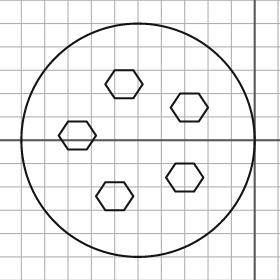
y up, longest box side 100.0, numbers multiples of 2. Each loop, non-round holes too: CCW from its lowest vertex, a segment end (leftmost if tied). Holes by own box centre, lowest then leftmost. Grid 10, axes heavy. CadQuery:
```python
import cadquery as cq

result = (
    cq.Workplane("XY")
    .moveTo(-50.0, 0.0)
    .circle(50.0)
    .moveTo(-64.0, -30.0)
    .lineTo(-56.0, -30.0)
    .lineTo(-52.0, -24.0)
    .lineTo(-56.0, -18.0)
    .lineTo(-64.0, -18.0)
    .lineTo(-68.0, -24.0)
    .close()
    .moveTo(-34.0, -22.0)
    .lineTo(-26.0, -22.0)
    .lineTo(-22.0, -16.0)
    .lineTo(-26.0, -10.0)
    .lineTo(-34.0, -10.0)
    .lineTo(-38.0, -16.0)
    .close()
    .moveTo(-80.0, -4.0)
    .lineTo(-72.0, -4.0)
    .lineTo(-68.0, 2.0)
    .lineTo(-72.0, 8.0)
    .lineTo(-80.0, 8.0)
    .lineTo(-84.0, 2.0)
    .close()
    .moveTo(-32.0, 8.0)
    .lineTo(-24.0, 8.0)
    .lineTo(-20.0, 14.0)
    .lineTo(-24.0, 20.0)
    .lineTo(-32.0, 20.0)
    .lineTo(-36.0, 14.0)
    .close()
    .moveTo(-60.0, 18.0)
    .lineTo(-52.0, 18.0)
    .lineTo(-48.0, 24.0)
    .lineTo(-52.0, 30.0)
    .lineTo(-60.0, 30.0)
    .lineTo(-64.0, 24.0)
    .close()
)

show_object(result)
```